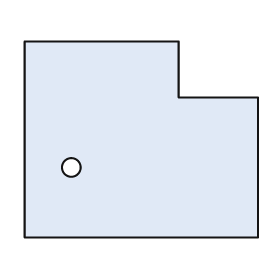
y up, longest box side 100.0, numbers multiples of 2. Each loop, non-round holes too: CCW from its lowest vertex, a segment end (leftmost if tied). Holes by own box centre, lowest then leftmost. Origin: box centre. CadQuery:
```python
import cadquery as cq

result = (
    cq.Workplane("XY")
    .moveTo(-50.0, -42.0)
    .lineTo(50.0, -42.0)
    .lineTo(50.0, 18.0)
    .lineTo(16.0, 18.0)
    .lineTo(16.0, 42.0)
    .lineTo(-50.0, 42.0)
    .close()
    .moveTo(-30.0, -12.0)
    .circle(4.0)
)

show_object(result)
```